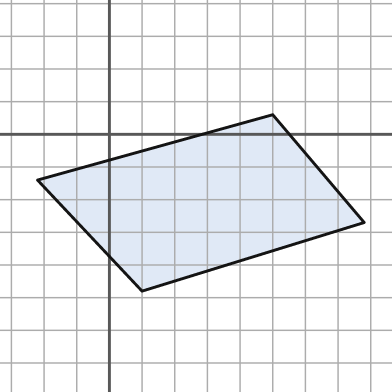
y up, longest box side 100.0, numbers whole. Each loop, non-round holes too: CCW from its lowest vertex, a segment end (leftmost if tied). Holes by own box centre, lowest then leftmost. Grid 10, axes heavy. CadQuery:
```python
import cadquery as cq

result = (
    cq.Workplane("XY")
    .moveTo(10.0, -48.0)
    .lineTo(78.0, -27.0)
    .lineTo(50.0, 6.0)
    .lineTo(-22.0, -14.0)
    .close()
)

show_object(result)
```